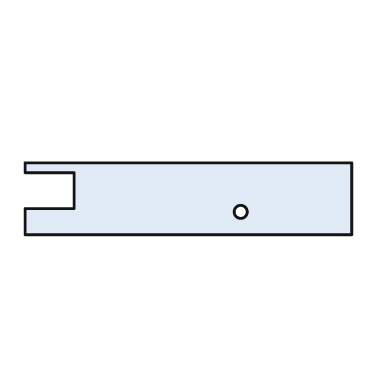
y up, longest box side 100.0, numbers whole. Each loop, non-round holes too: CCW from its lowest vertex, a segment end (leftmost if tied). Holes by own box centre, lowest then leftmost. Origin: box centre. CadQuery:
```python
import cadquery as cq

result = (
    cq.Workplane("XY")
    .moveTo(-50.0, -11.0)
    .lineTo(50.0, -11.0)
    .lineTo(50.0, 11.0)
    .lineTo(-50.0, 11.0)
    .lineTo(-50.0, 8.0)
    .lineTo(-35.0, 8.0)
    .lineTo(-35.0, -3.0)
    .lineTo(-50.0, -3.0)
    .close()
    .moveTo(16.0, -4.0)
    .circle(2.0)
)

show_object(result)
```